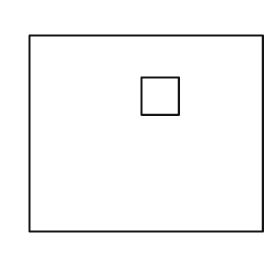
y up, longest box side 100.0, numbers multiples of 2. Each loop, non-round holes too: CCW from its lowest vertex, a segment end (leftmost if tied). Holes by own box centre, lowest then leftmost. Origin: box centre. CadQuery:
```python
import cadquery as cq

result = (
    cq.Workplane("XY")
    .moveTo(-50.0, -42.0)
    .lineTo(50.0, -42.0)
    .lineTo(50.0, 42.0)
    .lineTo(-50.0, 42.0)
    .close()
    .moveTo(-2.0, 8.0)
    .lineTo(14.0, 8.0)
    .lineTo(14.0, 24.0)
    .lineTo(-2.0, 24.0)
    .close()
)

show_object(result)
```